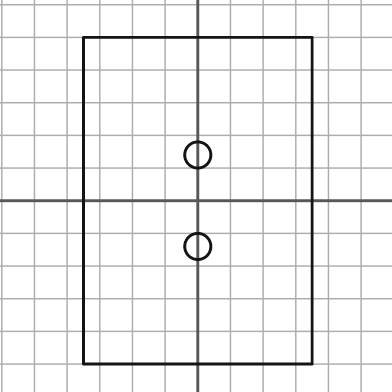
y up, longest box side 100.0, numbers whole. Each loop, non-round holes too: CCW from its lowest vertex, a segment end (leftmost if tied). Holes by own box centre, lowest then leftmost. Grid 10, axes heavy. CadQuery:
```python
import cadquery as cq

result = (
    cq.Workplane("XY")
    .moveTo(-35.0, -50.0)
    .lineTo(35.0, -50.0)
    .lineTo(35.0, 50.0)
    .lineTo(-35.0, 50.0)
    .close()
    .moveTo(0.0, -14.0)
    .circle(4.0)
    .moveTo(0.0, 14.0)
    .circle(4.0)
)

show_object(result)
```